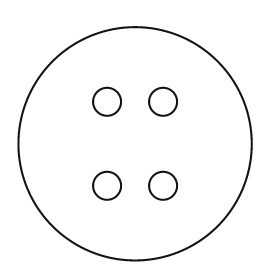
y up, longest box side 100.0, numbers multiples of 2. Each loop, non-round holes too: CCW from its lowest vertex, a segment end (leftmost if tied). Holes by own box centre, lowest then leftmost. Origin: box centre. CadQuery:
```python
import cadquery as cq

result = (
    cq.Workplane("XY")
    .moveTo(0.0, 0.0)
    .circle(50.0)
    .moveTo(-12.0, -18.0)
    .circle(6.0)
    .moveTo(12.0, -18.0)
    .circle(6.0)
    .moveTo(-12.0, 18.0)
    .circle(6.0)
    .moveTo(12.0, 18.0)
    .circle(6.0)
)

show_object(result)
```